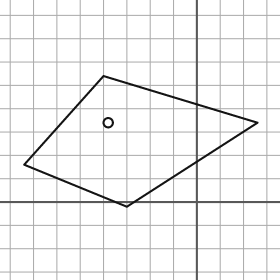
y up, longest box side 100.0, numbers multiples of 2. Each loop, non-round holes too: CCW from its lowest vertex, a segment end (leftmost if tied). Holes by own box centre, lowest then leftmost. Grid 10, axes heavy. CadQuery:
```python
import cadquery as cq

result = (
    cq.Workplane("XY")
    .moveTo(-30.0, -2.0)
    .lineTo(26.0, 34.0)
    .lineTo(-40.0, 54.0)
    .lineTo(-74.0, 16.0)
    .close()
    .moveTo(-38.0, 34.0)
    .circle(2.0)
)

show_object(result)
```